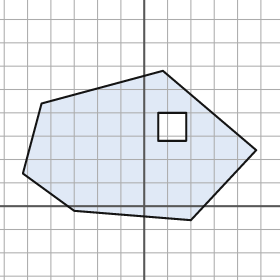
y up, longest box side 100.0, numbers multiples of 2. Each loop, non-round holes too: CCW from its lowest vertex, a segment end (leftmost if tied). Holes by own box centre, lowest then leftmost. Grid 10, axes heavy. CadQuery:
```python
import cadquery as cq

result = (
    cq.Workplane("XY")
    .moveTo(20.0, -6.0)
    .lineTo(48.0, 24.0)
    .lineTo(8.0, 58.0)
    .lineTo(-44.0, 44.0)
    .lineTo(-52.0, 14.0)
    .lineTo(-30.0, -2.0)
    .close()
    .moveTo(6.0, 28.0)
    .lineTo(18.0, 28.0)
    .lineTo(18.0, 40.0)
    .lineTo(6.0, 40.0)
    .close()
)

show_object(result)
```